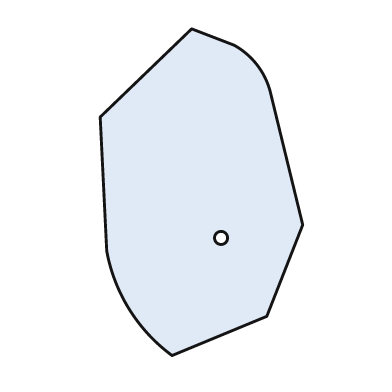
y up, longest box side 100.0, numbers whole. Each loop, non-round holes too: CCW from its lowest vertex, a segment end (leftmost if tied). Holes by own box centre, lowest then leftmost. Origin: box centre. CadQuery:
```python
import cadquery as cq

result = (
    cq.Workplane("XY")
    .moveTo(-9.0, -50.0)
    .lineTo(20.0, -38.0)
    .lineTo(31.0, -10.0)
    .lineTo(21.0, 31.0)
    .threePointArc((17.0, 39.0), (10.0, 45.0))
    .lineTo(-3.0, 50.0)
    .lineTo(-31.0, 23.0)
    .lineTo(-29.0, -18.0)
    .threePointArc((-22.0, -36.0), (-9.0, -50.0))
    .close()
    .moveTo(6.0, -14.0)
    .circle(2.0)
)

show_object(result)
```